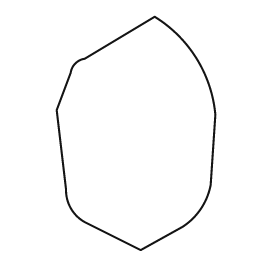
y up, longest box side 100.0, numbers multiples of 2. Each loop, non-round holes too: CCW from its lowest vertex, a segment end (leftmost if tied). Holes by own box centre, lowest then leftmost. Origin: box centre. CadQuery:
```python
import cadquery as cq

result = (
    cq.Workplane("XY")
    .moveTo(2.0, -50.0)
    .lineTo(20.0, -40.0)
    .threePointArc((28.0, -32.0), (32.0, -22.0))
    .lineTo(34.0, 8.0)
    .threePointArc((26.0, 32.0), (8.0, 50.0))
    .lineTo(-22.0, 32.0)
    .threePointArc((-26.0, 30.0), (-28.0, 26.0))
    .lineTo(-34.0, 10.0)
    .lineTo(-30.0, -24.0)
    .threePointArc((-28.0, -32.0), (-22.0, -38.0))
    .close()
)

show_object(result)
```